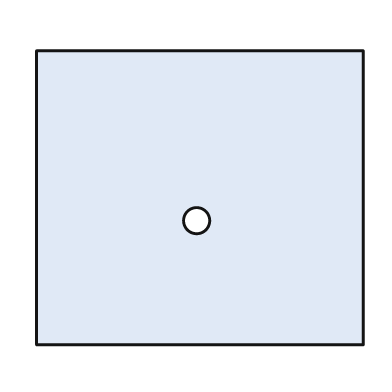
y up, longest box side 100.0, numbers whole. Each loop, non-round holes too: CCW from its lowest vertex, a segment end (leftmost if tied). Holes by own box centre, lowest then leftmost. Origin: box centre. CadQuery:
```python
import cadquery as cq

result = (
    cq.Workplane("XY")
    .moveTo(-50.0, -45.0)
    .lineTo(50.0, -45.0)
    .lineTo(50.0, 45.0)
    .lineTo(-50.0, 45.0)
    .close()
    .moveTo(-1.0, -7.0)
    .circle(4.0)
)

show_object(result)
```